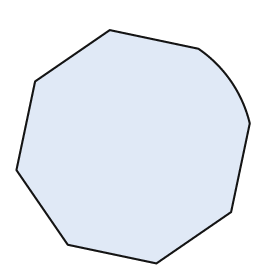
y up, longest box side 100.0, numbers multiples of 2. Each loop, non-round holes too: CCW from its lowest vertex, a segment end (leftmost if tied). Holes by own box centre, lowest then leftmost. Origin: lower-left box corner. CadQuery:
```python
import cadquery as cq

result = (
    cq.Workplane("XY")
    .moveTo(60.0, 0.0)
    .lineTo(92.0, 22.0)
    .lineTo(100.0, 60.0)
    .threePointArc((92.0, 78.0), (78.0, 92.0))
    .lineTo(40.0, 100.0)
    .lineTo(8.0, 78.0)
    .lineTo(0.0, 40.0)
    .lineTo(22.0, 8.0)
    .close()
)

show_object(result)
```